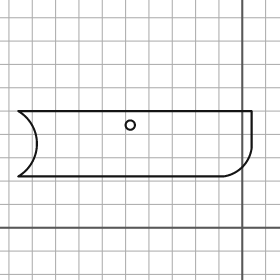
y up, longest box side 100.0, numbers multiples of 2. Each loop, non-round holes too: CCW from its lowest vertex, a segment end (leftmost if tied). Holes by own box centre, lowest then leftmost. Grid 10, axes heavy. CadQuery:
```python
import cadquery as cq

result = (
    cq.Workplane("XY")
    .moveTo(-96.0, 22.0)
    .lineTo(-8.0, 22.0)
    .threePointArc((0.0, 26.0), (4.0, 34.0))
    .lineTo(4.0, 50.0)
    .lineTo(-96.0, 50.0)
    .threePointArc((-88.0, 36.0), (-96.0, 22.0))
    .close()
    .moveTo(-48.0, 44.0)
    .circle(2.0)
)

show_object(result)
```